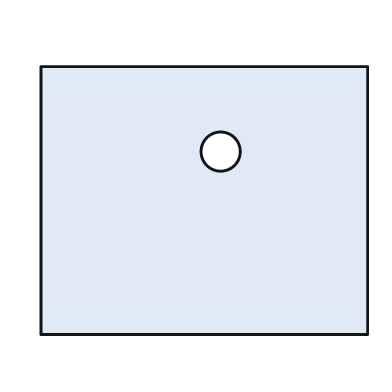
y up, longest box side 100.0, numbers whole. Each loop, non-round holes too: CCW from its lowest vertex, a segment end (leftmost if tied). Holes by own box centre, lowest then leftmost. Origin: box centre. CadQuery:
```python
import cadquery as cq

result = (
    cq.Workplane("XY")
    .moveTo(-50.0, -41.0)
    .lineTo(50.0, -41.0)
    .lineTo(50.0, 41.0)
    .lineTo(-50.0, 41.0)
    .close()
    .moveTo(5.0, 15.0)
    .circle(6.0)
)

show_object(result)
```